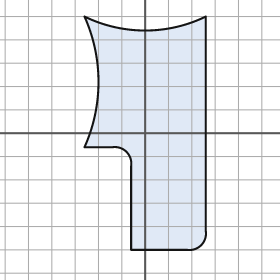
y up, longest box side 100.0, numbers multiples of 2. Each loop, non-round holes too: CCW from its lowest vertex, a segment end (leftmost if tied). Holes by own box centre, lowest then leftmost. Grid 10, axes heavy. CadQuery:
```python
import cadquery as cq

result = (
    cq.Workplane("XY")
    .moveTo(-6.0, -50.0)
    .lineTo(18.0, -50.0)
    .threePointArc((24.0, -48.0), (26.0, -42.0))
    .lineTo(26.0, 50.0)
    .threePointArc((0.0, 44.0), (-26.0, 50.0))
    .threePointArc((-20.0, 22.0), (-26.0, -6.0))
    .lineTo(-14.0, -6.0)
    .threePointArc((-8.0, -8.0), (-6.0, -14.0))
    .close()
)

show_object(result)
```